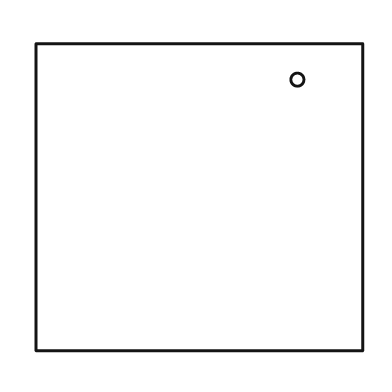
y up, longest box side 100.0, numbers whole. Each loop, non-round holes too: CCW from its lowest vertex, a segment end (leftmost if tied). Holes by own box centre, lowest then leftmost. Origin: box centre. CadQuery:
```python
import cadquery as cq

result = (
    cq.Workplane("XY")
    .moveTo(-50.0, -47.0)
    .lineTo(50.0, -47.0)
    .lineTo(50.0, 47.0)
    .lineTo(-50.0, 47.0)
    .close()
    .moveTo(30.0, 36.0)
    .circle(2.0)
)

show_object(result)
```